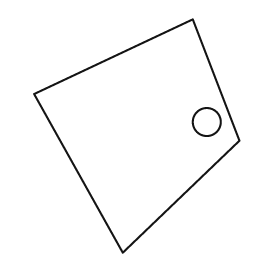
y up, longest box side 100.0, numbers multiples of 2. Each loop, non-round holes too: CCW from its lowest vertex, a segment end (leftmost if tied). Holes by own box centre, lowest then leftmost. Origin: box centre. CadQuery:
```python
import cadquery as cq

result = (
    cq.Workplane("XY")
    .moveTo(-6.0, -50.0)
    .lineTo(44.0, -2.0)
    .lineTo(24.0, 50.0)
    .lineTo(-44.0, 18.0)
    .close()
    .moveTo(30.0, 6.0)
    .circle(6.0)
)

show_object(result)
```